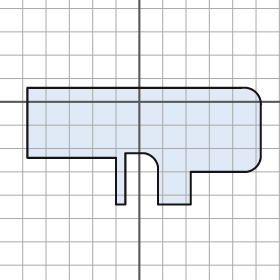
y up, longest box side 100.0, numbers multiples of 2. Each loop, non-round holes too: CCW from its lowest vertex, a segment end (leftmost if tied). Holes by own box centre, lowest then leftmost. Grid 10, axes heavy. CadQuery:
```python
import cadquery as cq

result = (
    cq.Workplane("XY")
    .moveTo(-10.0, -44.0)
    .lineTo(-6.0, -44.0)
    .lineTo(-6.0, -22.0)
    .lineTo(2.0, -22.0)
    .threePointArc((6.0, -24.0), (8.0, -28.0))
    .lineTo(8.0, -44.0)
    .lineTo(22.0, -44.0)
    .lineTo(22.0, -30.0)
    .lineTo(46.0, -30.0)
    .threePointArc((50.0, -28.0), (52.0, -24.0))
    .lineTo(52.0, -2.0)
    .threePointArc((50.0, 4.0), (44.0, 6.0))
    .lineTo(-48.0, 6.0)
    .lineTo(-48.0, -24.0)
    .lineTo(-10.0, -24.0)
    .close()
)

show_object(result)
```